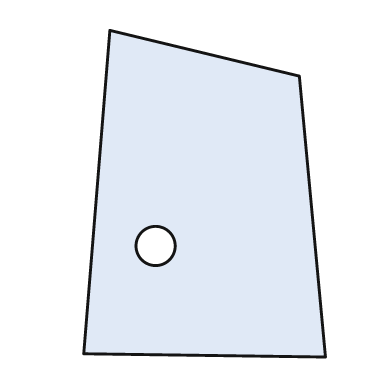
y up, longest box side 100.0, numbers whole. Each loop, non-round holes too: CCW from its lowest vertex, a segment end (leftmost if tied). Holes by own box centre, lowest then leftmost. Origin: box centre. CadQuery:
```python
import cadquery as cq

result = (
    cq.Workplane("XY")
    .moveTo(37.0, -50.0)
    .lineTo(29.0, 36.0)
    .lineTo(-29.0, 50.0)
    .lineTo(-37.0, -49.0)
    .close()
    .moveTo(-15.0, -16.0)
    .circle(6.0)
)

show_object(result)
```